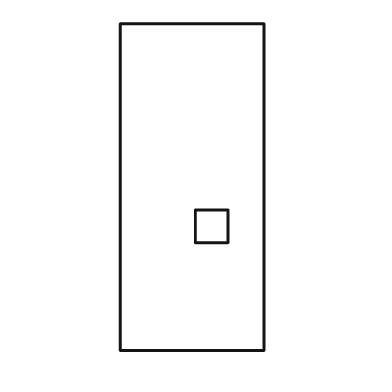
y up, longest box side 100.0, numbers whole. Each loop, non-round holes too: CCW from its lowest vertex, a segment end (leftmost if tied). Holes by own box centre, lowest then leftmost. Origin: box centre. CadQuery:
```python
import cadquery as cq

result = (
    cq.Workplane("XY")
    .moveTo(-22.0, -50.0)
    .lineTo(22.0, -50.0)
    .lineTo(22.0, 50.0)
    .lineTo(-22.0, 50.0)
    .close()
    .moveTo(1.0, -17.0)
    .lineTo(11.0, -17.0)
    .lineTo(11.0, -7.0)
    .lineTo(1.0, -7.0)
    .close()
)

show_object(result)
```